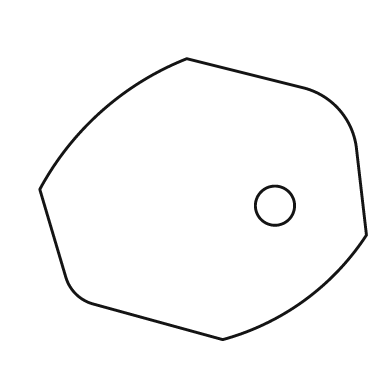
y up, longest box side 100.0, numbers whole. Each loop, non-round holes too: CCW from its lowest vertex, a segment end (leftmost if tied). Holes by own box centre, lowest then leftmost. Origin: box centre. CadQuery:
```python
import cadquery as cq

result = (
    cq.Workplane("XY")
    .moveTo(6.0, -43.0)
    .threePointArc((31.0, -31.0), (50.0, -11.0))
    .lineTo(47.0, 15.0)
    .threePointArc((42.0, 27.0), (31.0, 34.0))
    .lineTo(-5.0, 43.0)
    .threePointArc((-31.0, 27.0), (-50.0, 3.0))
    .lineTo(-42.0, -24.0)
    .threePointArc((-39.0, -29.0), (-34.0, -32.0))
    .close()
    .moveTo(22.0, -2.0)
    .circle(6.0)
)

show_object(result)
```